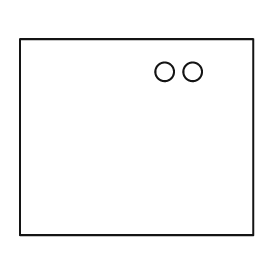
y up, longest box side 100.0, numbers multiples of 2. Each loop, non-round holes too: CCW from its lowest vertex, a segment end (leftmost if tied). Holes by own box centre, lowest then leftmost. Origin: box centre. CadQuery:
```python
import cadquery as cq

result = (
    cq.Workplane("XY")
    .moveTo(-50.0, -42.0)
    .lineTo(50.0, -42.0)
    .lineTo(50.0, 42.0)
    .lineTo(-50.0, 42.0)
    .close()
    .moveTo(12.0, 28.0)
    .circle(4.0)
    .moveTo(24.0, 28.0)
    .circle(4.0)
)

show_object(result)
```